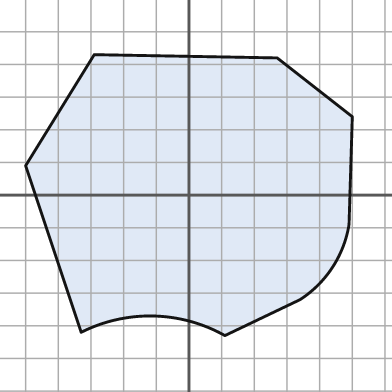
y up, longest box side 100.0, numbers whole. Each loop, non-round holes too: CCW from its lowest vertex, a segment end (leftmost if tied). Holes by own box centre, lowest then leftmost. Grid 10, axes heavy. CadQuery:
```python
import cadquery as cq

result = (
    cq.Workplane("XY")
    .moveTo(11.0, -43.0)
    .lineTo(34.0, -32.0)
    .threePointArc((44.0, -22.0), (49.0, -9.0))
    .lineTo(50.0, 24.0)
    .lineTo(27.0, 42.0)
    .lineTo(-29.0, 43.0)
    .lineTo(-50.0, 9.0)
    .lineTo(-33.0, -42.0)
    .threePointArc((-11.0, -37.0), (11.0, -43.0))
    .close()
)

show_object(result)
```